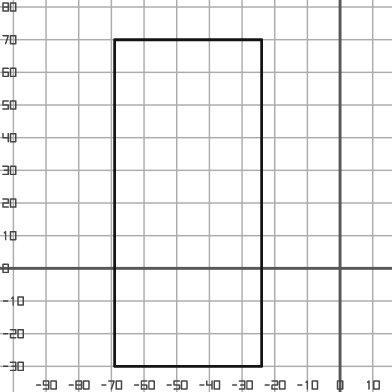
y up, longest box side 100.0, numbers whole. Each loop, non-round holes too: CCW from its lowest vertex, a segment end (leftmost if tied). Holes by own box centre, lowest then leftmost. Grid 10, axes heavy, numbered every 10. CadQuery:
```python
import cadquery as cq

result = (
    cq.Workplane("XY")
    .moveTo(-69.0, -30.0)
    .lineTo(-24.0, -30.0)
    .lineTo(-24.0, 70.0)
    .lineTo(-69.0, 70.0)
    .close()
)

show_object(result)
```